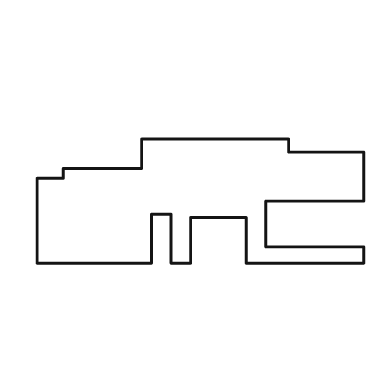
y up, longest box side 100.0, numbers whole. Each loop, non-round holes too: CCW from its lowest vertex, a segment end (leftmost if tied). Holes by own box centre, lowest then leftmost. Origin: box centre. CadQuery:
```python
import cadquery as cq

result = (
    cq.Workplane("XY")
    .moveTo(-50.0, -19.0)
    .lineTo(-15.0, -19.0)
    .lineTo(-15.0, -4.0)
    .lineTo(-9.0, -4.0)
    .lineTo(-9.0, -19.0)
    .lineTo(-3.0, -19.0)
    .lineTo(-3.0, -5.0)
    .lineTo(14.0, -5.0)
    .lineTo(14.0, -19.0)
    .lineTo(50.0, -19.0)
    .lineTo(50.0, -14.0)
    .lineTo(20.0, -14.0)
    .lineTo(20.0, 0.0)
    .lineTo(50.0, 0.0)
    .lineTo(50.0, 15.0)
    .lineTo(27.0, 15.0)
    .lineTo(27.0, 19.0)
    .lineTo(-18.0, 19.0)
    .lineTo(-18.0, 10.0)
    .lineTo(-42.0, 10.0)
    .lineTo(-42.0, 7.0)
    .lineTo(-50.0, 7.0)
    .close()
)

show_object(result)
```